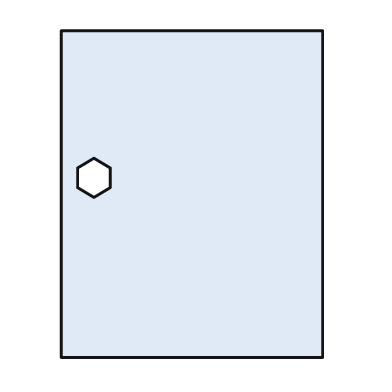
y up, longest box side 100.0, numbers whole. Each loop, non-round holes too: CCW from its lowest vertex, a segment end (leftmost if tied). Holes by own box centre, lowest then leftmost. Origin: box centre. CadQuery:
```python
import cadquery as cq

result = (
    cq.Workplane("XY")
    .moveTo(-40.0, -50.0)
    .lineTo(40.0, -50.0)
    .lineTo(40.0, 50.0)
    .lineTo(-40.0, 50.0)
    .close()
    .moveTo(-30.0, -1.0)
    .lineTo(-25.0, 2.0)
    .lineTo(-25.0, 8.0)
    .lineTo(-30.0, 11.0)
    .lineTo(-35.0, 8.0)
    .lineTo(-35.0, 2.0)
    .close()
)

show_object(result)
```